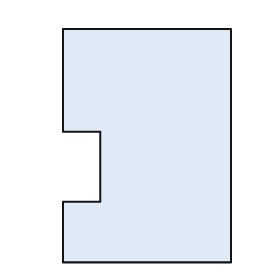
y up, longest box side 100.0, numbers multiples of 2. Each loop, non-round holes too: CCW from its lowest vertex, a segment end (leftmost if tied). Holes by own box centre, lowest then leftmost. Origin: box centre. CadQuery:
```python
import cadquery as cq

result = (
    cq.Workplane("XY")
    .moveTo(-36.0, -50.0)
    .lineTo(36.0, -50.0)
    .lineTo(36.0, 50.0)
    .lineTo(-36.0, 50.0)
    .lineTo(-36.0, 6.0)
    .lineTo(-20.0, 6.0)
    .lineTo(-20.0, -24.0)
    .lineTo(-36.0, -24.0)
    .close()
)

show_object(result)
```